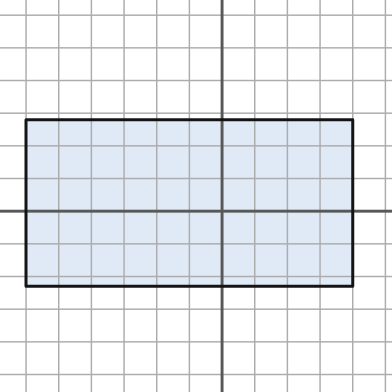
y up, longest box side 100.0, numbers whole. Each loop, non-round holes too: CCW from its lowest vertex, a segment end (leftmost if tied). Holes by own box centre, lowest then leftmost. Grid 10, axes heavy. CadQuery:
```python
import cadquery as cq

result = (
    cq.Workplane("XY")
    .moveTo(-60.0, -23.0)
    .lineTo(40.0, -23.0)
    .lineTo(40.0, 28.0)
    .lineTo(-60.0, 28.0)
    .close()
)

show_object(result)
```